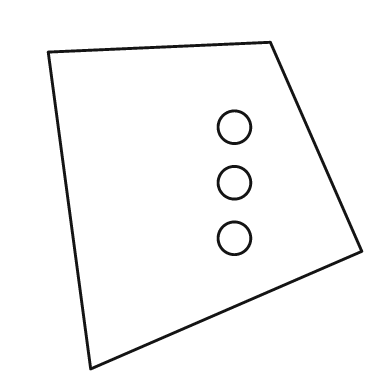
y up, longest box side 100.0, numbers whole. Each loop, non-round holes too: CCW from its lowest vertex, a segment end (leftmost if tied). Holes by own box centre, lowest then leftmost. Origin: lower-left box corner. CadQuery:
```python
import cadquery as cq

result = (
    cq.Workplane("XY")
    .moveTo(13.0, 0.0)
    .lineTo(96.0, 36.0)
    .lineTo(68.0, 100.0)
    .lineTo(0.0, 97.0)
    .close()
    .moveTo(57.0, 40.0)
    .circle(5.0)
    .moveTo(57.0, 57.0)
    .circle(5.0)
    .moveTo(57.0, 74.0)
    .circle(5.0)
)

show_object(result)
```